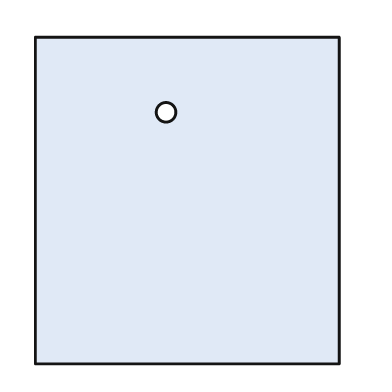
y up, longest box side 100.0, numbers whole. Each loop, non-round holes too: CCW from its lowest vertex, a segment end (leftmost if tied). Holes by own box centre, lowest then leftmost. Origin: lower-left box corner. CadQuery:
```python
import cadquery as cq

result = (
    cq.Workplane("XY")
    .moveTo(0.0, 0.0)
    .lineTo(93.0, 0.0)
    .lineTo(93.0, 100.0)
    .lineTo(0.0, 100.0)
    .close()
    .moveTo(40.0, 77.0)
    .circle(3.0)
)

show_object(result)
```